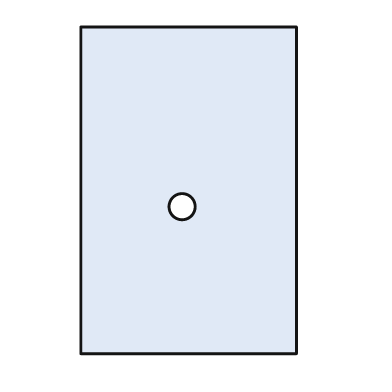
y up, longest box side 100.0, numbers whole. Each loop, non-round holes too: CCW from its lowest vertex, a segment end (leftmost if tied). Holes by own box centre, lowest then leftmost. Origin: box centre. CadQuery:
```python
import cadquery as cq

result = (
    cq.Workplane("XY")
    .moveTo(-33.0, -50.0)
    .lineTo(33.0, -50.0)
    .lineTo(33.0, 50.0)
    .lineTo(-33.0, 50.0)
    .close()
    .moveTo(-2.0, -5.0)
    .circle(4.0)
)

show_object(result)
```